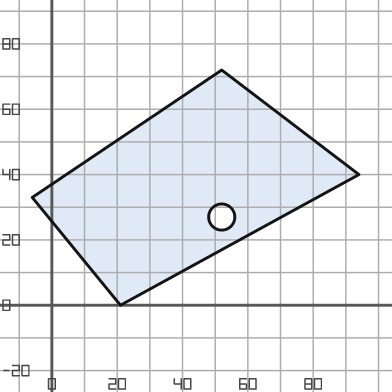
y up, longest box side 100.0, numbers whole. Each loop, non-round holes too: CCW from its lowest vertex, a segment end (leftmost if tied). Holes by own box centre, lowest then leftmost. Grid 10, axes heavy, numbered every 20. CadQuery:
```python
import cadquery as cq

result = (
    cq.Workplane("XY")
    .moveTo(21.0, 0.0)
    .lineTo(94.0, 40.0)
    .lineTo(52.0, 72.0)
    .lineTo(-6.0, 33.0)
    .close()
    .moveTo(52.0, 27.0)
    .circle(4.0)
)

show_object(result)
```